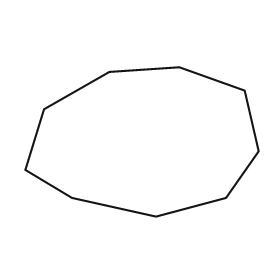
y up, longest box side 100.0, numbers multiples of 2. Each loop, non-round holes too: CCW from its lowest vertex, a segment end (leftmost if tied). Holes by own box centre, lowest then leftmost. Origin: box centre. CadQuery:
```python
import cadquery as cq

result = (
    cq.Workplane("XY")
    .moveTo(6.0, -32.0)
    .lineTo(36.0, -24.0)
    .lineTo(50.0, -4.0)
    .lineTo(44.0, 22.0)
    .lineTo(16.0, 32.0)
    .lineTo(-14.0, 30.0)
    .lineTo(-42.0, 14.0)
    .lineTo(-50.0, -12.0)
    .lineTo(-30.0, -24.0)
    .close()
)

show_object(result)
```